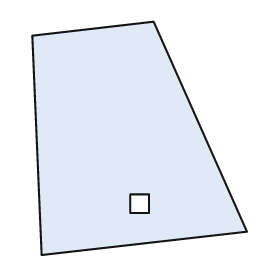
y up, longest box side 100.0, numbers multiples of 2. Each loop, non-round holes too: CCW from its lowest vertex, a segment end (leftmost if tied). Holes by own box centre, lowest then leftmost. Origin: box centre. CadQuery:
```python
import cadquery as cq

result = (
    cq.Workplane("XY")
    .moveTo(-42.0, -50.0)
    .lineTo(46.0, -40.0)
    .lineTo(6.0, 50.0)
    .lineTo(-46.0, 44.0)
    .close()
    .moveTo(-4.0, -32.0)
    .lineTo(4.0, -32.0)
    .lineTo(4.0, -24.0)
    .lineTo(-4.0, -24.0)
    .close()
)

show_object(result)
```